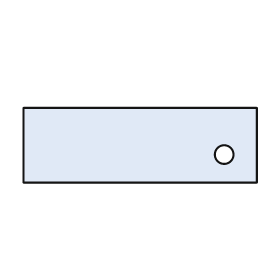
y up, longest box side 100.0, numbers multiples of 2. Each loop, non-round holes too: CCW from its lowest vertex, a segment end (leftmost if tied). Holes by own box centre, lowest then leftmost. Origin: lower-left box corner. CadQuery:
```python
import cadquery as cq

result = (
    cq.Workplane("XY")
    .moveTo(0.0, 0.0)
    .lineTo(100.0, 0.0)
    .lineTo(100.0, 32.0)
    .lineTo(0.0, 32.0)
    .close()
    .moveTo(86.0, 12.0)
    .circle(4.0)
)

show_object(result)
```